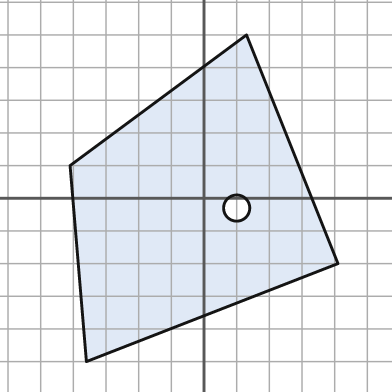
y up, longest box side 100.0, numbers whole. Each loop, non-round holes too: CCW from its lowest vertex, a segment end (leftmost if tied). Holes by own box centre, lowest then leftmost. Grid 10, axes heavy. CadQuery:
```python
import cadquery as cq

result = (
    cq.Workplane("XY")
    .moveTo(-36.0, -50.0)
    .lineTo(41.0, -20.0)
    .lineTo(13.0, 50.0)
    .lineTo(-41.0, 10.0)
    .close()
    .moveTo(10.0, -3.0)
    .circle(4.0)
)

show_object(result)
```